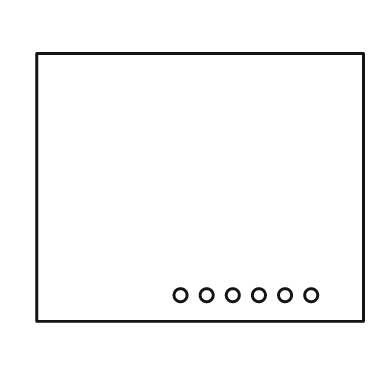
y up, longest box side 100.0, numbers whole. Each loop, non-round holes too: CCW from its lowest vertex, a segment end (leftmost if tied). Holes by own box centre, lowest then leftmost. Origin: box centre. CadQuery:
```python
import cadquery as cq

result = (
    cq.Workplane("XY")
    .moveTo(-50.0, -41.0)
    .lineTo(50.0, -41.0)
    .lineTo(50.0, 41.0)
    .lineTo(-50.0, 41.0)
    .close()
    .moveTo(-6.0, -33.0)
    .circle(2.0)
    .moveTo(2.0, -33.0)
    .circle(2.0)
    .moveTo(10.0, -33.0)
    .circle(2.0)
    .moveTo(18.0, -33.0)
    .circle(2.0)
    .moveTo(26.0, -33.0)
    .circle(2.0)
    .moveTo(34.0, -33.0)
    .circle(2.0)
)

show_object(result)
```